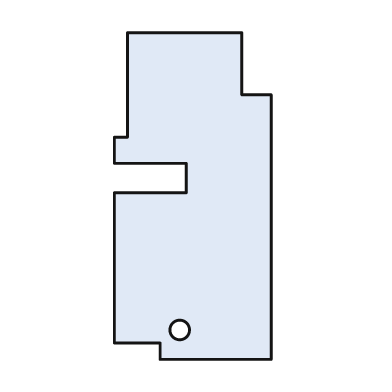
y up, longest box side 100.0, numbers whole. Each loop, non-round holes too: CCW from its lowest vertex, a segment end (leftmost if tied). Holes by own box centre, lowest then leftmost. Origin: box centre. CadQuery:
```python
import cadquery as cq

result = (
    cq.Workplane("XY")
    .moveTo(-10.0, -50.0)
    .lineTo(24.0, -50.0)
    .lineTo(24.0, 31.0)
    .lineTo(15.0, 31.0)
    .lineTo(15.0, 50.0)
    .lineTo(-20.0, 50.0)
    .lineTo(-20.0, 18.0)
    .lineTo(-24.0, 18.0)
    .lineTo(-24.0, 10.0)
    .lineTo(-2.0, 10.0)
    .lineTo(-2.0, 1.0)
    .lineTo(-24.0, 1.0)
    .lineTo(-24.0, -45.0)
    .lineTo(-10.0, -45.0)
    .close()
    .moveTo(-4.0, -41.0)
    .circle(3.0)
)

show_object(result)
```